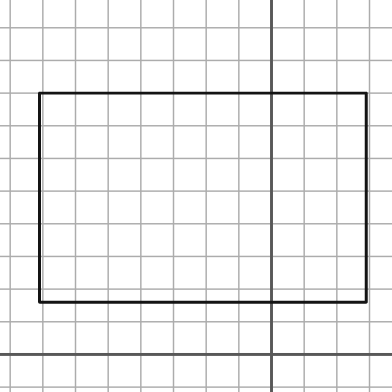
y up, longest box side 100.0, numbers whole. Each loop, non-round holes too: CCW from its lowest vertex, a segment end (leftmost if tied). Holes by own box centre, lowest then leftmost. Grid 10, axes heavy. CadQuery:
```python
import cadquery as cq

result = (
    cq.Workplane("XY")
    .moveTo(-71.0, 16.0)
    .lineTo(29.0, 16.0)
    .lineTo(29.0, 80.0)
    .lineTo(-71.0, 80.0)
    .close()
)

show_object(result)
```